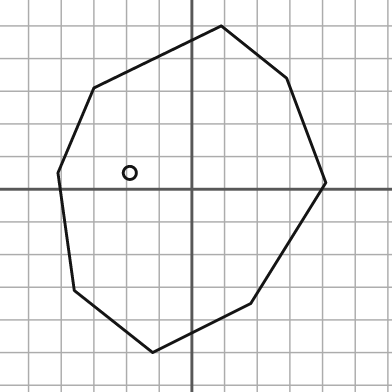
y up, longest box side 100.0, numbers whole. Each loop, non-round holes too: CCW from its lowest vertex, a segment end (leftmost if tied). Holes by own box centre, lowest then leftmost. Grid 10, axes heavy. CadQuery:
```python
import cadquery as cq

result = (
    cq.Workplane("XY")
    .moveTo(-12.0, -50.0)
    .lineTo(18.0, -35.0)
    .lineTo(41.0, 2.0)
    .lineTo(29.0, 34.0)
    .lineTo(9.0, 50.0)
    .lineTo(-30.0, 31.0)
    .lineTo(-41.0, 5.0)
    .lineTo(-36.0, -31.0)
    .close()
    .moveTo(-19.0, 5.0)
    .circle(2.0)
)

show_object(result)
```